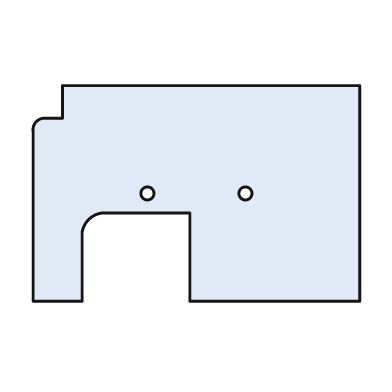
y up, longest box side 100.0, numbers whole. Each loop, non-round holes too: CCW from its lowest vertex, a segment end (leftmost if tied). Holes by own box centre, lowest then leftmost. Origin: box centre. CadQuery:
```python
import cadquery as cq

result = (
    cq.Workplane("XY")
    .moveTo(-50.0, -33.0)
    .lineTo(-35.0, -33.0)
    .lineTo(-35.0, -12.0)
    .threePointArc((-33.0, -8.0), (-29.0, -6.0))
    .lineTo(-2.0, -6.0)
    .lineTo(-2.0, -33.0)
    .lineTo(50.0, -33.0)
    .lineTo(50.0, 33.0)
    .lineTo(-41.0, 33.0)
    .lineTo(-41.0, 23.0)
    .lineTo(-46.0, 23.0)
    .threePointArc((-49.0, 22.0), (-50.0, 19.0))
    .close()
    .moveTo(-15.0, 0.0)
    .circle(2.0)
    .moveTo(15.0, 0.0)
    .circle(2.0)
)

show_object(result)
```